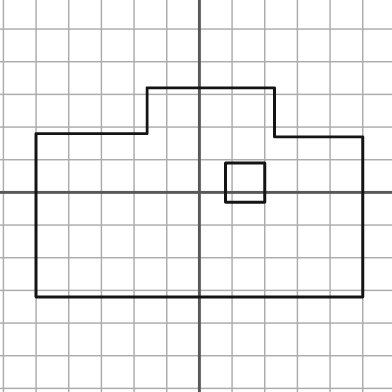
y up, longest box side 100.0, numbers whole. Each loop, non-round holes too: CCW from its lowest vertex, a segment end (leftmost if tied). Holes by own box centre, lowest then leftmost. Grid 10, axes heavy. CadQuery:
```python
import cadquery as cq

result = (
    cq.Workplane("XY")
    .moveTo(-50.0, -32.0)
    .lineTo(50.0, -32.0)
    .lineTo(50.0, 17.0)
    .lineTo(23.0, 17.0)
    .lineTo(23.0, 32.0)
    .lineTo(-16.0, 32.0)
    .lineTo(-16.0, 18.0)
    .lineTo(-50.0, 18.0)
    .close()
    .moveTo(8.0, -3.0)
    .lineTo(20.0, -3.0)
    .lineTo(20.0, 9.0)
    .lineTo(8.0, 9.0)
    .close()
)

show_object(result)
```